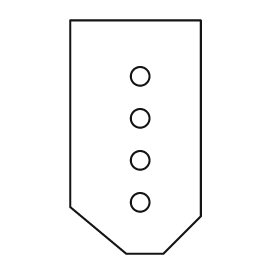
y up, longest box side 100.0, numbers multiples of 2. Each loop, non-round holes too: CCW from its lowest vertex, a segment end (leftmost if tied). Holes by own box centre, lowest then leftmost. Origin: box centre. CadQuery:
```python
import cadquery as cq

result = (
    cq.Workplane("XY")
    .moveTo(-4.0, -50.0)
    .lineTo(12.0, -50.0)
    .lineTo(28.0, -34.0)
    .lineTo(28.0, 50.0)
    .lineTo(-28.0, 50.0)
    .lineTo(-28.0, -30.0)
    .close()
    .moveTo(2.0, -28.0)
    .circle(4.0)
    .moveTo(2.0, -10.0)
    .circle(4.0)
    .moveTo(2.0, 8.0)
    .circle(4.0)
    .moveTo(2.0, 26.0)
    .circle(4.0)
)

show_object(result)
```